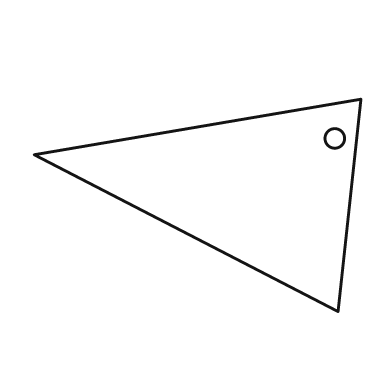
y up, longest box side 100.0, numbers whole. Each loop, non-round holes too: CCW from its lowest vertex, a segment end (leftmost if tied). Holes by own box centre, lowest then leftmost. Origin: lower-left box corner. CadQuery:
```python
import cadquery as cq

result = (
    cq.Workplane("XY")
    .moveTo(93.0, 0.0)
    .lineTo(100.0, 65.0)
    .lineTo(0.0, 48.0)
    .close()
    .moveTo(92.0, 53.0)
    .circle(3.0)
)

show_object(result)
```